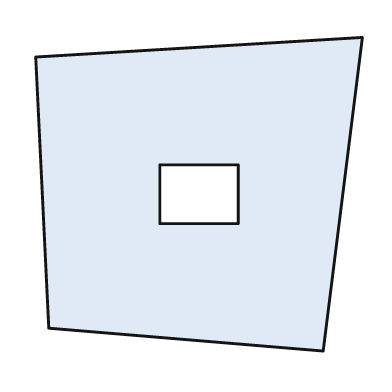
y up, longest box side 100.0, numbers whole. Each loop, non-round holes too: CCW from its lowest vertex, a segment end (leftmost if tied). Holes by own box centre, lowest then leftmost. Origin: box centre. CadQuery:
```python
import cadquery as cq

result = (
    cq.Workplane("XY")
    .moveTo(38.0, -48.0)
    .lineTo(50.0, 48.0)
    .lineTo(-50.0, 42.0)
    .lineTo(-46.0, -41.0)
    .close()
    .moveTo(-12.0, -9.0)
    .lineTo(12.0, -9.0)
    .lineTo(12.0, 9.0)
    .lineTo(-12.0, 9.0)
    .close()
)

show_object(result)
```